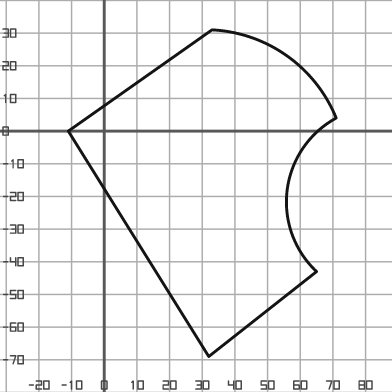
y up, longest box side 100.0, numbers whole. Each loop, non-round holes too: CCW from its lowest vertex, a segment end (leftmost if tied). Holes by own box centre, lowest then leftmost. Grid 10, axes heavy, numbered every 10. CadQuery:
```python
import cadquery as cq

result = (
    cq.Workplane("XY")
    .moveTo(32.0, -69.0)
    .lineTo(65.0, -43.0)
    .threePointArc((56.0, -18.0), (71.0, 4.0))
    .threePointArc((56.0, 23.0), (33.0, 31.0))
    .lineTo(-11.0, 0.0)
    .close()
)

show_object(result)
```